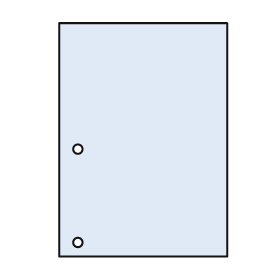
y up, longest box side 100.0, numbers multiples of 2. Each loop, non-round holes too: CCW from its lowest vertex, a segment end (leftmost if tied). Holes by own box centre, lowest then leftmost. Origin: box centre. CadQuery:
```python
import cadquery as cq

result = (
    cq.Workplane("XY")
    .moveTo(-36.0, -50.0)
    .lineTo(36.0, -50.0)
    .lineTo(36.0, 50.0)
    .lineTo(-36.0, 50.0)
    .close()
    .moveTo(-28.0, -44.0)
    .circle(2.0)
    .moveTo(-28.0, -4.0)
    .circle(2.0)
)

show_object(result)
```